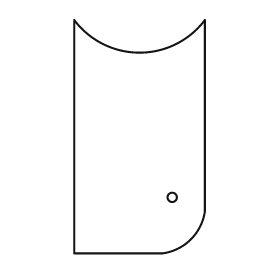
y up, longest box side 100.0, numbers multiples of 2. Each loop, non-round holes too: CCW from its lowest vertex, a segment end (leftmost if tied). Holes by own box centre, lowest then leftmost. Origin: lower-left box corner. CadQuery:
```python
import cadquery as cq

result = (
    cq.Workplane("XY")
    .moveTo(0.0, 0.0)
    .lineTo(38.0, 0.0)
    .threePointArc((50.0, 6.0), (56.0, 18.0))
    .lineTo(56.0, 100.0)
    .threePointArc((28.0, 86.0), (0.0, 100.0))
    .close()
    .moveTo(42.0, 24.0)
    .circle(2.0)
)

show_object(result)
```